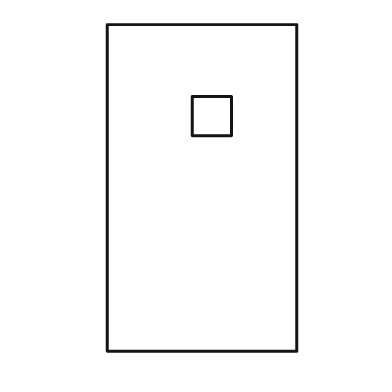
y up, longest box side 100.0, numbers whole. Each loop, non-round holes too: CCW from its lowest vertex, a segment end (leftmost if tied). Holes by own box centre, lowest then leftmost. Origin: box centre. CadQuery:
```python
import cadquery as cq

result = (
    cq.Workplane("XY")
    .moveTo(-29.0, -50.0)
    .lineTo(29.0, -50.0)
    .lineTo(29.0, 50.0)
    .lineTo(-29.0, 50.0)
    .close()
    .moveTo(-3.0, 16.0)
    .lineTo(9.0, 16.0)
    .lineTo(9.0, 28.0)
    .lineTo(-3.0, 28.0)
    .close()
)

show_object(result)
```